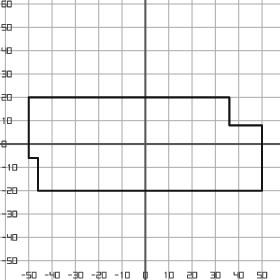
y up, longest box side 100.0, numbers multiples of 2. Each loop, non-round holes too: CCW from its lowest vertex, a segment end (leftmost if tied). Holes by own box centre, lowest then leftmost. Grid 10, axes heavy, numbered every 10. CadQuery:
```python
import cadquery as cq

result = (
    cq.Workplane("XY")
    .moveTo(-46.0, -20.0)
    .lineTo(50.0, -20.0)
    .lineTo(50.0, 8.0)
    .lineTo(36.0, 8.0)
    .lineTo(36.0, 20.0)
    .lineTo(-50.0, 20.0)
    .lineTo(-50.0, -6.0)
    .lineTo(-46.0, -6.0)
    .close()
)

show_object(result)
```